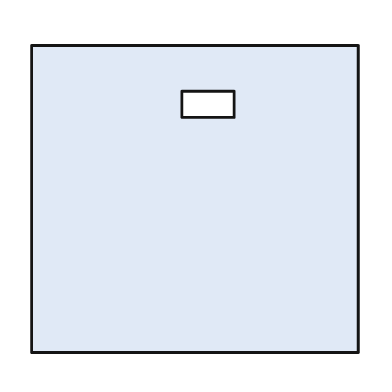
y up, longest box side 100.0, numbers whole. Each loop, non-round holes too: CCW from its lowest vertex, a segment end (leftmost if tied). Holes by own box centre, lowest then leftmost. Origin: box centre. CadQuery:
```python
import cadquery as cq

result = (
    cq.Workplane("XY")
    .moveTo(-50.0, -47.0)
    .lineTo(50.0, -47.0)
    .lineTo(50.0, 47.0)
    .lineTo(-50.0, 47.0)
    .close()
    .moveTo(-4.0, 25.0)
    .lineTo(12.0, 25.0)
    .lineTo(12.0, 33.0)
    .lineTo(-4.0, 33.0)
    .close()
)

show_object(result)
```